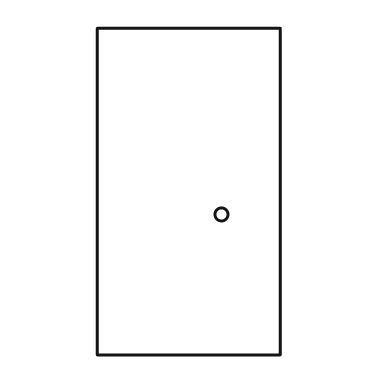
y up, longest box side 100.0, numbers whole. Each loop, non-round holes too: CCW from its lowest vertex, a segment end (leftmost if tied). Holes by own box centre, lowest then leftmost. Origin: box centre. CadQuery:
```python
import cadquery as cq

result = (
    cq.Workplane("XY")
    .moveTo(-28.0, -50.0)
    .lineTo(28.0, -50.0)
    .lineTo(28.0, 50.0)
    .lineTo(-28.0, 50.0)
    .close()
    .moveTo(10.0, -7.0)
    .circle(2.0)
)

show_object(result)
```